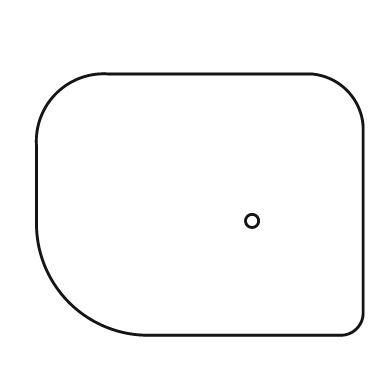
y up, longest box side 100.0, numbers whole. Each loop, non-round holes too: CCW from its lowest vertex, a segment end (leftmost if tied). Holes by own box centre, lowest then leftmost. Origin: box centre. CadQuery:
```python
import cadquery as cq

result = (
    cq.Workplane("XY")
    .moveTo(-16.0, -40.0)
    .lineTo(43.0, -40.0)
    .threePointArc((48.0, -38.0), (50.0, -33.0))
    .lineTo(50.0, 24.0)
    .threePointArc((45.0, 35.0), (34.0, 40.0))
    .lineTo(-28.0, 40.0)
    .threePointArc((-44.0, 34.0), (-50.0, 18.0))
    .lineTo(-50.0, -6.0)
    .threePointArc((-40.0, -30.0), (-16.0, -40.0))
    .close()
    .moveTo(16.0, -5.0)
    .circle(2.0)
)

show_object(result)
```